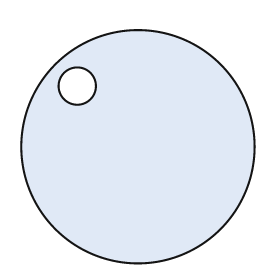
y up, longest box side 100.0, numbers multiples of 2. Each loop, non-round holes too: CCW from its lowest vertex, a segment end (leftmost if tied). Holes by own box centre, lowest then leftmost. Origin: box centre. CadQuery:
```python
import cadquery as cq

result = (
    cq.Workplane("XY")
    .moveTo(0.0, 0.0)
    .circle(50.0)
    .moveTo(-26.0, 26.0)
    .circle(8.0)
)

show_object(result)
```